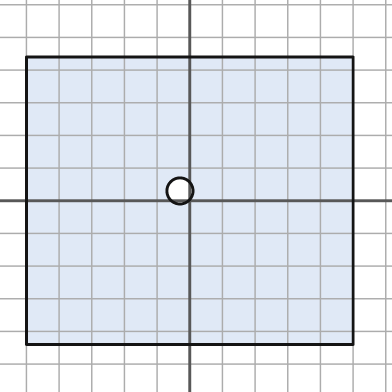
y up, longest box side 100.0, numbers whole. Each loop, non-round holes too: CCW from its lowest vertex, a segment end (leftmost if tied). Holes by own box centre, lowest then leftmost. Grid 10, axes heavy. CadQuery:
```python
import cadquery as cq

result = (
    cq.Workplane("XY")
    .moveTo(-50.0, -44.0)
    .lineTo(50.0, -44.0)
    .lineTo(50.0, 44.0)
    .lineTo(-50.0, 44.0)
    .close()
    .moveTo(-3.0, 3.0)
    .circle(4.0)
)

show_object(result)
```